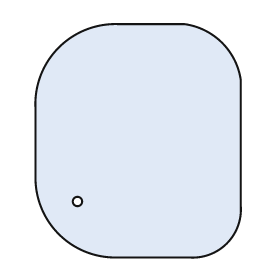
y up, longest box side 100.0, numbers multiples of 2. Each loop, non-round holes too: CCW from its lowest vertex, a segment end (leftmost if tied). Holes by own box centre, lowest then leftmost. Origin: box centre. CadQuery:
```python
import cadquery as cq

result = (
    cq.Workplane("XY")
    .moveTo(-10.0, -50.0)
    .lineTo(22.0, -50.0)
    .threePointArc((38.0, -44.0), (44.0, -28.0))
    .lineTo(44.0, 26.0)
    .threePointArc((36.0, 42.0), (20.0, 50.0))
    .lineTo(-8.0, 50.0)
    .threePointArc((-34.0, 40.0), (-44.0, 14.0))
    .lineTo(-44.0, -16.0)
    .threePointArc((-34.0, -40.0), (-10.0, -50.0))
    .close()
    .moveTo(-26.0, -26.0)
    .circle(2.0)
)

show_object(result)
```